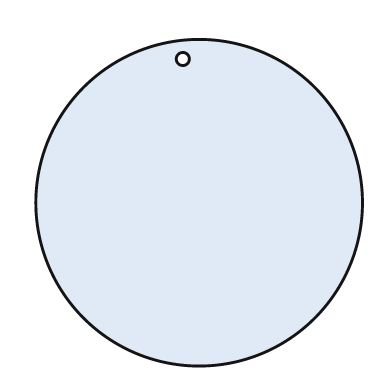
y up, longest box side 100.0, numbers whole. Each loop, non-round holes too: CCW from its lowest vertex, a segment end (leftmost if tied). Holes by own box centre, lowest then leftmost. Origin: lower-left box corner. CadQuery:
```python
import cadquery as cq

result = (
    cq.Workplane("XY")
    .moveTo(50.0, 50.0)
    .circle(50.0)
    .moveTo(45.0, 94.0)
    .circle(2.0)
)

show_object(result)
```